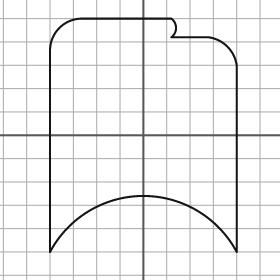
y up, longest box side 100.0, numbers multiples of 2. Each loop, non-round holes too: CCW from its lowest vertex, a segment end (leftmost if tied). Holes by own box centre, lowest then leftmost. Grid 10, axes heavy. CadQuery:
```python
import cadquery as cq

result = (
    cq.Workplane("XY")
    .moveTo(-40.0, -50.0)
    .threePointArc((0.0, -26.0), (40.0, -50.0))
    .lineTo(40.0, 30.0)
    .threePointArc((36.0, 38.0), (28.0, 42.0))
    .lineTo(12.0, 42.0)
    .threePointArc((14.0, 46.0), (12.0, 50.0))
    .lineTo(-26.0, 50.0)
    .threePointArc((-36.0, 46.0), (-40.0, 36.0))
    .close()
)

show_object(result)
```